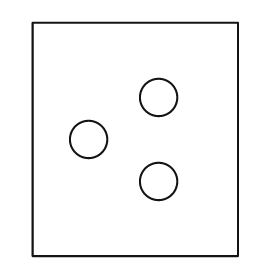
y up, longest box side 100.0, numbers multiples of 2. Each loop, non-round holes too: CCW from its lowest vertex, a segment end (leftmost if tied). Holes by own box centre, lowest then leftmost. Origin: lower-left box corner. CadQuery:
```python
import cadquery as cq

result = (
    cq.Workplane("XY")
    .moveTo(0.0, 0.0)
    .lineTo(88.0, 0.0)
    .lineTo(88.0, 100.0)
    .lineTo(0.0, 100.0)
    .close()
    .moveTo(54.0, 32.0)
    .circle(8.0)
    .moveTo(24.0, 50.0)
    .circle(8.0)
    .moveTo(54.0, 68.0)
    .circle(8.0)
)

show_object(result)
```